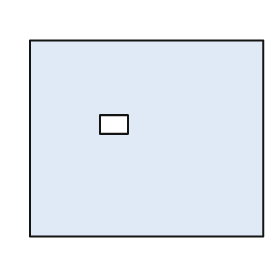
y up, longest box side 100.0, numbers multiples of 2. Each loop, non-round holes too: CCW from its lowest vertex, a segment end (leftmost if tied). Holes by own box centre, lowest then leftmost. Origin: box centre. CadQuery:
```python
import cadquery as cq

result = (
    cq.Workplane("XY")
    .moveTo(-50.0, -42.0)
    .lineTo(50.0, -42.0)
    .lineTo(50.0, 42.0)
    .lineTo(-50.0, 42.0)
    .close()
    .moveTo(-20.0, 2.0)
    .lineTo(-8.0, 2.0)
    .lineTo(-8.0, 10.0)
    .lineTo(-20.0, 10.0)
    .close()
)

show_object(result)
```